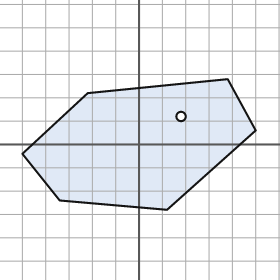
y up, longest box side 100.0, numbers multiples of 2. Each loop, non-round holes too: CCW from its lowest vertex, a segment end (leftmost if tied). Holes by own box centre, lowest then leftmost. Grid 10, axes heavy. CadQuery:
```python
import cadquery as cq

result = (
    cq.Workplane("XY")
    .moveTo(12.0, -28.0)
    .lineTo(50.0, 6.0)
    .lineTo(38.0, 28.0)
    .lineTo(-22.0, 22.0)
    .lineTo(-50.0, -4.0)
    .lineTo(-34.0, -24.0)
    .close()
    .moveTo(18.0, 12.0)
    .circle(2.0)
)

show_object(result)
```